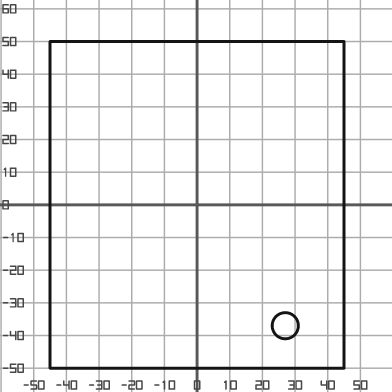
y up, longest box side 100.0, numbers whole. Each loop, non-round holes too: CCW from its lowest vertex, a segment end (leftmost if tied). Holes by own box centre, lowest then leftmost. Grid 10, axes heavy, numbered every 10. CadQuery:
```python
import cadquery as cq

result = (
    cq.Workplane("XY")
    .moveTo(-45.0, -50.0)
    .lineTo(45.0, -50.0)
    .lineTo(45.0, 50.0)
    .lineTo(-45.0, 50.0)
    .close()
    .moveTo(27.0, -37.0)
    .circle(4.0)
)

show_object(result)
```